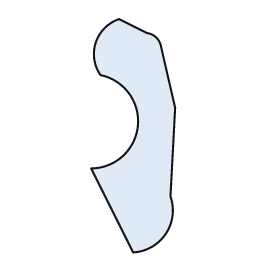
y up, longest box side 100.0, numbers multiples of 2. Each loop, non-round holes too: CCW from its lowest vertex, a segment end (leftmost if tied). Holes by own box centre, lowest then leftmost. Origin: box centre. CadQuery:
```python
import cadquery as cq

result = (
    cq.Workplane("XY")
    .moveTo(0.0, -50.0)
    .threePointArc((14.0, -42.0), (16.0, -26.0))
    .lineTo(18.0, 12.0)
    .lineTo(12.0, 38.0)
    .threePointArc((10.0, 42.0), (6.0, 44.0))
    .lineTo(-6.0, 50.0)
    .threePointArc((-16.0, 40.0), (-14.0, 26.0))
    .threePointArc((2.0, 4.0), (-18.0, -14.0))
    .close()
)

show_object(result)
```